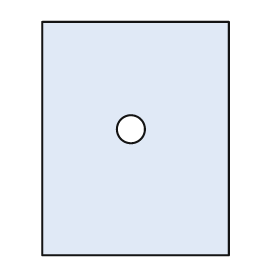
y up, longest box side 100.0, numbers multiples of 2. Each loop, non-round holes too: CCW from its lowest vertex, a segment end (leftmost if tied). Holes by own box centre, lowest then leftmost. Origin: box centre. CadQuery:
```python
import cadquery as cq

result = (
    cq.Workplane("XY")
    .moveTo(-40.0, -50.0)
    .lineTo(40.0, -50.0)
    .lineTo(40.0, 50.0)
    .lineTo(-40.0, 50.0)
    .close()
    .moveTo(-2.0, 4.0)
    .circle(6.0)
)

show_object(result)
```